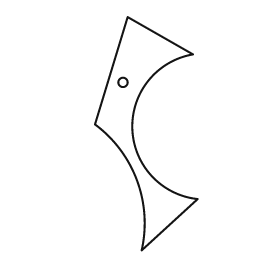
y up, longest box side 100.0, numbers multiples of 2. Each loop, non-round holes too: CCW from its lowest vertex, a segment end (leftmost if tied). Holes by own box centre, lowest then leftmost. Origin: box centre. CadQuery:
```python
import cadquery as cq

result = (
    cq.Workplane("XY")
    .moveTo(-2.0, -50.0)
    .lineTo(22.0, -28.0)
    .threePointArc((-6.0, 2.0), (20.0, 34.0))
    .lineTo(-8.0, 50.0)
    .lineTo(-22.0, 4.0)
    .threePointArc((-4.0, -20.0), (-2.0, -50.0))
    .close()
    .moveTo(-10.0, 22.0)
    .circle(2.0)
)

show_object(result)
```